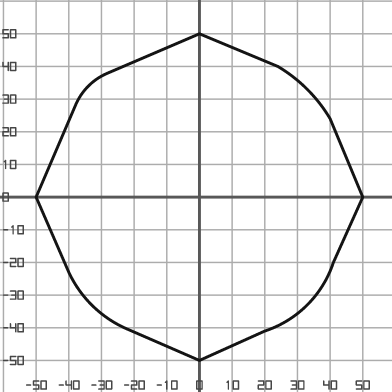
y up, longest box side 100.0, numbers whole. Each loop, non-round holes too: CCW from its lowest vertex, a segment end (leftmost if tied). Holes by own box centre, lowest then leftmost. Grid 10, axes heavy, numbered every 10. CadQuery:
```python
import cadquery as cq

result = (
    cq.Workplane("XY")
    .moveTo(0.0, -50.0)
    .lineTo(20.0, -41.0)
    .threePointArc((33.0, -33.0), (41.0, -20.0))
    .lineTo(50.0, 0.0)
    .lineTo(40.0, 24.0)
    .threePointArc((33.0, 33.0), (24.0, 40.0))
    .lineTo(0.0, 50.0)
    .lineTo(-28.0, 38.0)
    .threePointArc((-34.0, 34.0), (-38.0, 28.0))
    .lineTo(-50.0, 0.0)
    .lineTo(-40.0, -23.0)
    .threePointArc((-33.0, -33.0), (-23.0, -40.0))
    .close()
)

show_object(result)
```